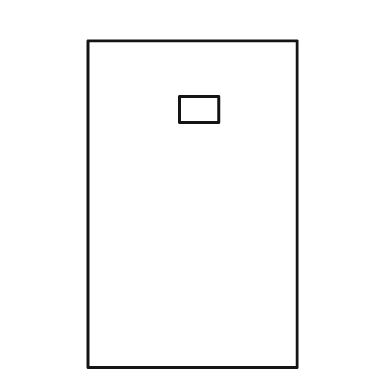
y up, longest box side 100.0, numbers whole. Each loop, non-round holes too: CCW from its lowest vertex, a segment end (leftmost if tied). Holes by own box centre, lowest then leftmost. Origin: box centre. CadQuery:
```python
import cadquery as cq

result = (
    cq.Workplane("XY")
    .moveTo(-32.0, -50.0)
    .lineTo(32.0, -50.0)
    .lineTo(32.0, 50.0)
    .lineTo(-32.0, 50.0)
    .close()
    .moveTo(-4.0, 25.0)
    .lineTo(8.0, 25.0)
    .lineTo(8.0, 33.0)
    .lineTo(-4.0, 33.0)
    .close()
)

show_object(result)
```